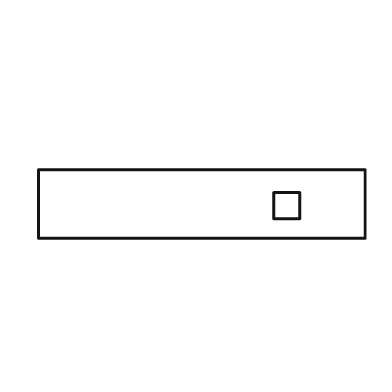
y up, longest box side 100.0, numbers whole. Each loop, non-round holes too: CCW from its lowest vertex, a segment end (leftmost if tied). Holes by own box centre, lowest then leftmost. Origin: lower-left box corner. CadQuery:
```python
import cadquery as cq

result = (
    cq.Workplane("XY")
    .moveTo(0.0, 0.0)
    .lineTo(100.0, 0.0)
    .lineTo(100.0, 21.0)
    .lineTo(0.0, 21.0)
    .close()
    .moveTo(72.0, 6.0)
    .lineTo(80.0, 6.0)
    .lineTo(80.0, 14.0)
    .lineTo(72.0, 14.0)
    .close()
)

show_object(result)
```